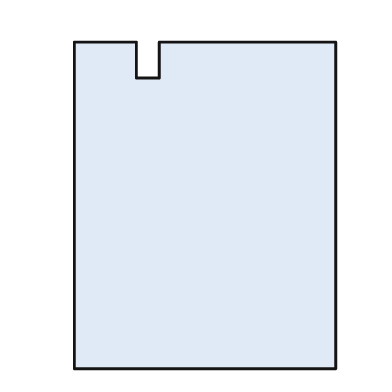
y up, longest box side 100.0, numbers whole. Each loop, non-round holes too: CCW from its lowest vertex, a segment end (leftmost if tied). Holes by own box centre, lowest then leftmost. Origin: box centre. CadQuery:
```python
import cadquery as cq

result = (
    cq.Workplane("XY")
    .moveTo(-40.0, -50.0)
    .lineTo(40.0, -50.0)
    .lineTo(40.0, 50.0)
    .lineTo(-14.0, 50.0)
    .lineTo(-14.0, 39.0)
    .lineTo(-21.0, 39.0)
    .lineTo(-21.0, 50.0)
    .lineTo(-40.0, 50.0)
    .close()
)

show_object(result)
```